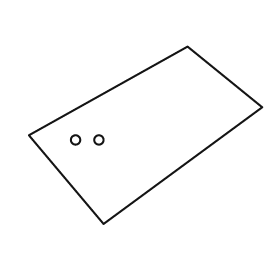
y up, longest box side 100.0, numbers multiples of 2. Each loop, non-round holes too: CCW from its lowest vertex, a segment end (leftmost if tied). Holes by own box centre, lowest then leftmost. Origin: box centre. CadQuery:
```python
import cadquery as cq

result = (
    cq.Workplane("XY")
    .moveTo(-18.0, -38.0)
    .lineTo(50.0, 12.0)
    .lineTo(18.0, 38.0)
    .lineTo(-50.0, 0.0)
    .close()
    .moveTo(-30.0, -2.0)
    .circle(2.0)
    .moveTo(-20.0, -2.0)
    .circle(2.0)
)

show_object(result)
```